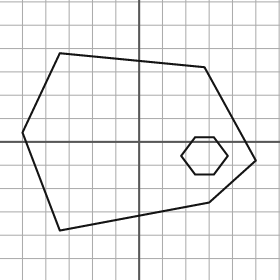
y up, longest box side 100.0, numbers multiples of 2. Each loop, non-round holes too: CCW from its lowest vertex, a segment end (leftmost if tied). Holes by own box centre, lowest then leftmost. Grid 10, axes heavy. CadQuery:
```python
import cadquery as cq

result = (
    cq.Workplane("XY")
    .moveTo(-34.0, -38.0)
    .lineTo(30.0, -26.0)
    .lineTo(50.0, -8.0)
    .lineTo(28.0, 32.0)
    .lineTo(-34.0, 38.0)
    .lineTo(-50.0, 4.0)
    .close()
    .moveTo(24.0, -14.0)
    .lineTo(32.0, -14.0)
    .lineTo(38.0, -6.0)
    .lineTo(32.0, 2.0)
    .lineTo(24.0, 2.0)
    .lineTo(18.0, -6.0)
    .close()
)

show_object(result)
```